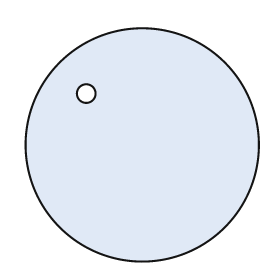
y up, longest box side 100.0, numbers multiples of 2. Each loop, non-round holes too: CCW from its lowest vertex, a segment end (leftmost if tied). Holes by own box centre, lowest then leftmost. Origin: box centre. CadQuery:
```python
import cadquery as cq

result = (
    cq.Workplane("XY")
    .moveTo(0.0, 0.0)
    .circle(50.0)
    .moveTo(-24.0, 22.0)
    .circle(4.0)
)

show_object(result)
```